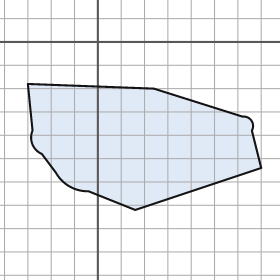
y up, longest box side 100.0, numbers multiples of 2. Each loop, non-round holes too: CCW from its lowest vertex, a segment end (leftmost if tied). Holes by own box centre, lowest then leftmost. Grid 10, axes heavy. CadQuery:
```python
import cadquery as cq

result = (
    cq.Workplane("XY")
    .moveTo(16.0, -72.0)
    .lineTo(70.0, -54.0)
    .lineTo(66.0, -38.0)
    .threePointArc((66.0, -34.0), (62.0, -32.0))
    .lineTo(24.0, -20.0)
    .lineTo(-30.0, -18.0)
    .lineTo(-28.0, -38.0)
    .threePointArc((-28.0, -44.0), (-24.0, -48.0))
    .lineTo(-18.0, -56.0)
    .threePointArc((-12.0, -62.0), (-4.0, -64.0))
    .close()
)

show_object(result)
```